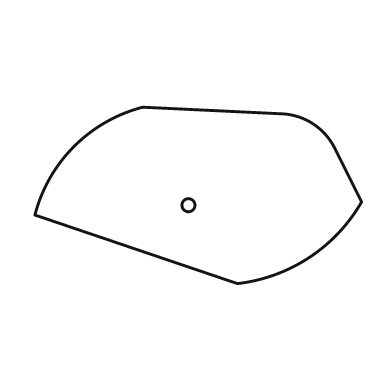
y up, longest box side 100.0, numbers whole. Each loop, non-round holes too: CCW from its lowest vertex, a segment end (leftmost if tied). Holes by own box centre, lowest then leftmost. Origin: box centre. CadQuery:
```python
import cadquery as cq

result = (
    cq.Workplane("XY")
    .moveTo(12.0, -27.0)
    .threePointArc((34.0, -19.0), (50.0, -2.0))
    .lineTo(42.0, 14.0)
    .threePointArc((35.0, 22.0), (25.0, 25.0))
    .lineTo(-17.0, 27.0)
    .threePointArc((-38.0, 15.0), (-50.0, -6.0))
    .close()
    .moveTo(-3.0, -3.0)
    .circle(2.0)
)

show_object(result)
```